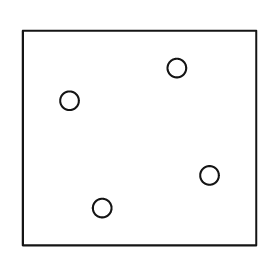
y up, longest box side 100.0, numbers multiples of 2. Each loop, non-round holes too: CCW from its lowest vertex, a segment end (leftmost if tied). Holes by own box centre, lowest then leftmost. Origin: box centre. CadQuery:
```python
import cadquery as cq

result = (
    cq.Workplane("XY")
    .moveTo(-50.0, -46.0)
    .lineTo(50.0, -46.0)
    .lineTo(50.0, 46.0)
    .lineTo(-50.0, 46.0)
    .close()
    .moveTo(-16.0, -30.0)
    .circle(4.0)
    .moveTo(30.0, -16.0)
    .circle(4.0)
    .moveTo(-30.0, 16.0)
    .circle(4.0)
    .moveTo(16.0, 30.0)
    .circle(4.0)
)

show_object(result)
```